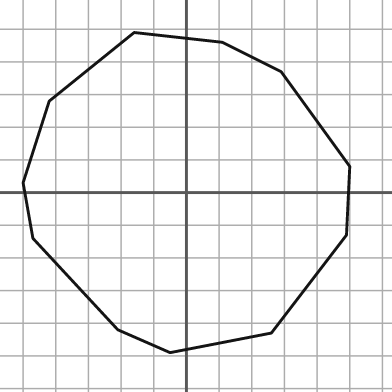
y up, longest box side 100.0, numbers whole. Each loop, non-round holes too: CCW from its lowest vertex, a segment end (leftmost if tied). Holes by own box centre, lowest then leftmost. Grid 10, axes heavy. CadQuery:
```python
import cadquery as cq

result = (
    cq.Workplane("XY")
    .moveTo(-5.0, -49.0)
    .lineTo(26.0, -43.0)
    .lineTo(49.0, -13.0)
    .lineTo(50.0, 8.0)
    .lineTo(29.0, 37.0)
    .lineTo(11.0, 46.0)
    .lineTo(-16.0, 49.0)
    .lineTo(-42.0, 28.0)
    .lineTo(-50.0, 3.0)
    .lineTo(-47.0, -14.0)
    .lineTo(-21.0, -42.0)
    .close()
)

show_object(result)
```